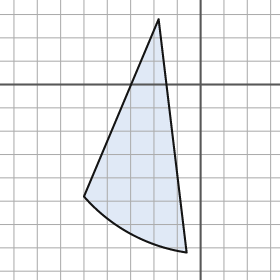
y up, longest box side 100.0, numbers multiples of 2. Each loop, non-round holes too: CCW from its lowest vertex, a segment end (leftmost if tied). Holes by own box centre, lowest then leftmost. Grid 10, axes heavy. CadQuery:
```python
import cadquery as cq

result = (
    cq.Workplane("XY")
    .moveTo(-6.0, -72.0)
    .lineTo(-18.0, 28.0)
    .lineTo(-50.0, -48.0)
    .threePointArc((-30.0, -64.0), (-6.0, -72.0))
    .close()
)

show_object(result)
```